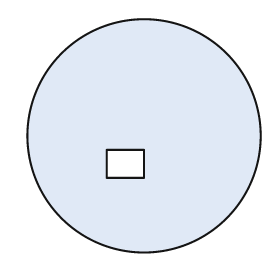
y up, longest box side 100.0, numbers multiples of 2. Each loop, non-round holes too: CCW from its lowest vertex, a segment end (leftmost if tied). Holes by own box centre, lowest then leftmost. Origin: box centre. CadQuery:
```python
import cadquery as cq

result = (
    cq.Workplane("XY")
    .moveTo(0.0, 0.0)
    .circle(50.0)
    .moveTo(-16.0, -18.0)
    .lineTo(0.0, -18.0)
    .lineTo(0.0, -6.0)
    .lineTo(-16.0, -6.0)
    .close()
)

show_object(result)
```